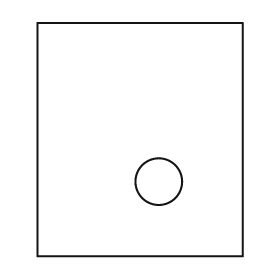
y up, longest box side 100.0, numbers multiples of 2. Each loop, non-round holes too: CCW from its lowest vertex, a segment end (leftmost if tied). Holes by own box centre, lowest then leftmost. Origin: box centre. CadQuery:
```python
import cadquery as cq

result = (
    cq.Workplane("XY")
    .moveTo(-44.0, -50.0)
    .lineTo(44.0, -50.0)
    .lineTo(44.0, 50.0)
    .lineTo(-44.0, 50.0)
    .close()
    .moveTo(8.0, -18.0)
    .circle(10.0)
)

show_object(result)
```